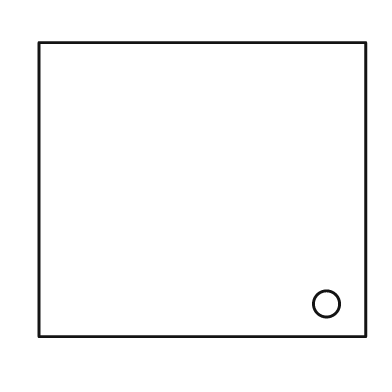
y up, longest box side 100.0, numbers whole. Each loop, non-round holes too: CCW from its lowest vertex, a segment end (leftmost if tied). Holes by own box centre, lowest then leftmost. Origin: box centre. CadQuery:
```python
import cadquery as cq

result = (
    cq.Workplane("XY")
    .moveTo(-50.0, -45.0)
    .lineTo(50.0, -45.0)
    .lineTo(50.0, 45.0)
    .lineTo(-50.0, 45.0)
    .close()
    .moveTo(38.0, -35.0)
    .circle(4.0)
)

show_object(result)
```